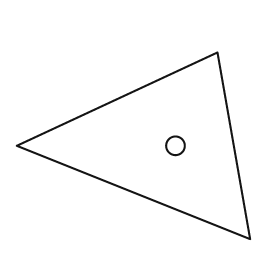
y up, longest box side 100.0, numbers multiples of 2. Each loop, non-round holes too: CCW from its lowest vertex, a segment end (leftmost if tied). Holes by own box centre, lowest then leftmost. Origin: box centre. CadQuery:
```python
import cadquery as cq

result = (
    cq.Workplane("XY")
    .moveTo(50.0, -40.0)
    .lineTo(36.0, 40.0)
    .lineTo(-50.0, 0.0)
    .close()
    .moveTo(18.0, 0.0)
    .circle(4.0)
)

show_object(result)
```